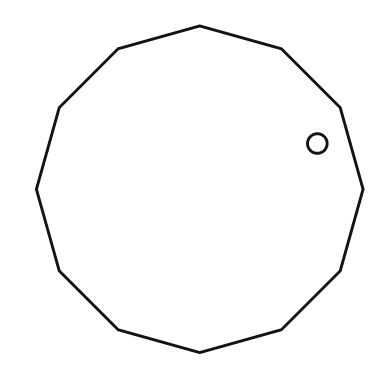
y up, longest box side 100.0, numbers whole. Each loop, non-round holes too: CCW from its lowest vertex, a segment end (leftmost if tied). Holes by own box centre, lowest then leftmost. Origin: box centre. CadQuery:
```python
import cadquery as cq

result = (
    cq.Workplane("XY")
    .moveTo(0.0, -50.0)
    .lineTo(25.0, -43.0)
    .lineTo(43.0, -25.0)
    .lineTo(50.0, 0.0)
    .lineTo(43.0, 25.0)
    .lineTo(25.0, 43.0)
    .lineTo(0.0, 50.0)
    .lineTo(-25.0, 43.0)
    .lineTo(-43.0, 25.0)
    .lineTo(-50.0, 0.0)
    .lineTo(-43.0, -25.0)
    .lineTo(-25.0, -43.0)
    .close()
    .moveTo(36.0, 14.0)
    .circle(3.0)
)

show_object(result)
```